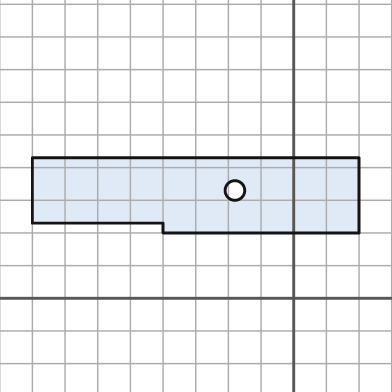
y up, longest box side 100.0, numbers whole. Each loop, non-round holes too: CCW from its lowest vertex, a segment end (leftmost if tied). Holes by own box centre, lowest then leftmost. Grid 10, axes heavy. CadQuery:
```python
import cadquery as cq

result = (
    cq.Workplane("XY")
    .moveTo(-40.0, 20.0)
    .lineTo(20.0, 20.0)
    .lineTo(20.0, 43.0)
    .lineTo(-80.0, 43.0)
    .lineTo(-80.0, 23.0)
    .lineTo(-40.0, 23.0)
    .close()
    .moveTo(-18.0, 33.0)
    .circle(3.0)
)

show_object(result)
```